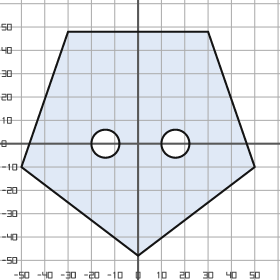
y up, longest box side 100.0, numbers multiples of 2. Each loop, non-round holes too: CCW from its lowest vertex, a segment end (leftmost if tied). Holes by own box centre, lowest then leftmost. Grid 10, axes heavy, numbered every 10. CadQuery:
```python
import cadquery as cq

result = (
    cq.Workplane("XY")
    .moveTo(0.0, -48.0)
    .lineTo(50.0, -10.0)
    .lineTo(30.0, 48.0)
    .lineTo(-30.0, 48.0)
    .lineTo(-50.0, -10.0)
    .close()
    .moveTo(-14.0, 0.0)
    .circle(6.0)
    .moveTo(16.0, 0.0)
    .circle(6.0)
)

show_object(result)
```